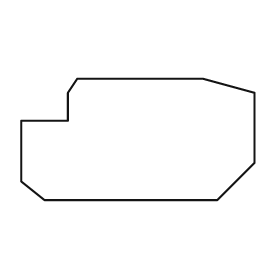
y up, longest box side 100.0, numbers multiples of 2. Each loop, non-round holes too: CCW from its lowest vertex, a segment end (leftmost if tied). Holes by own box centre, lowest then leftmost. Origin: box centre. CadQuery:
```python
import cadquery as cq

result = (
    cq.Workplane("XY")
    .moveTo(-40.0, -26.0)
    .lineTo(34.0, -26.0)
    .lineTo(50.0, -10.0)
    .lineTo(50.0, 20.0)
    .lineTo(28.0, 26.0)
    .lineTo(-26.0, 26.0)
    .lineTo(-30.0, 20.0)
    .lineTo(-30.0, 8.0)
    .lineTo(-50.0, 8.0)
    .lineTo(-50.0, -18.0)
    .close()
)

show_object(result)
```